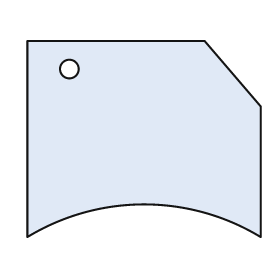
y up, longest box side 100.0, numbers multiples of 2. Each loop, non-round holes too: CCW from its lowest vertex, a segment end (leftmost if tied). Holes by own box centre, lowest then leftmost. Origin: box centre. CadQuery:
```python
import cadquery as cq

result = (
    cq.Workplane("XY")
    .moveTo(-50.0, -42.0)
    .threePointArc((0.0, -28.0), (50.0, -42.0))
    .lineTo(50.0, 14.0)
    .lineTo(26.0, 42.0)
    .lineTo(-50.0, 42.0)
    .close()
    .moveTo(-32.0, 30.0)
    .circle(4.0)
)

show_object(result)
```